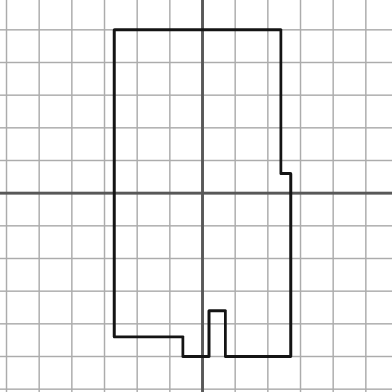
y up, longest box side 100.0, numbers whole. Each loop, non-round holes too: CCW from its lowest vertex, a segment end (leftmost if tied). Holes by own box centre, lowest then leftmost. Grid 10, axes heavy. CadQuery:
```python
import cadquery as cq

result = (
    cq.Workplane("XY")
    .moveTo(-6.0, -50.0)
    .lineTo(2.0, -50.0)
    .lineTo(2.0, -36.0)
    .lineTo(7.0, -36.0)
    .lineTo(7.0, -50.0)
    .lineTo(27.0, -50.0)
    .lineTo(27.0, 6.0)
    .lineTo(24.0, 6.0)
    .lineTo(24.0, 50.0)
    .lineTo(-27.0, 50.0)
    .lineTo(-27.0, -44.0)
    .lineTo(-6.0, -44.0)
    .close()
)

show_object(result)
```